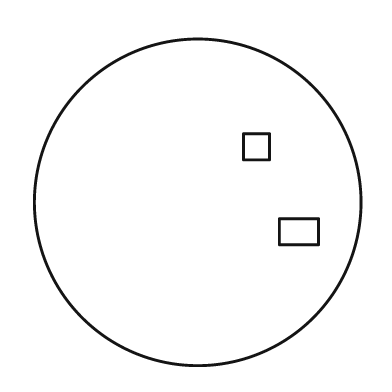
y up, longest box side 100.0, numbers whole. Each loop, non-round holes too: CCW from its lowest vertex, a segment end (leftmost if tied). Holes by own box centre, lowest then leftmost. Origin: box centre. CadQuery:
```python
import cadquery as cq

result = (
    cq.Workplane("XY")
    .moveTo(0.0, 0.0)
    .circle(50.0)
    .moveTo(25.0, -13.0)
    .lineTo(37.0, -13.0)
    .lineTo(37.0, -5.0)
    .lineTo(25.0, -5.0)
    .close()
    .moveTo(14.0, 13.0)
    .lineTo(22.0, 13.0)
    .lineTo(22.0, 21.0)
    .lineTo(14.0, 21.0)
    .close()
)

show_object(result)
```